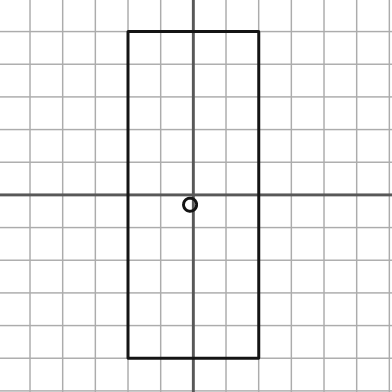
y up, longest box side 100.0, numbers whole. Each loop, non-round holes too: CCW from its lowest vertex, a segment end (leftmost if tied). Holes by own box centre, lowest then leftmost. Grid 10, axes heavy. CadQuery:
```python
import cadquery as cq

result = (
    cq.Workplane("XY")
    .moveTo(-20.0, -50.0)
    .lineTo(20.0, -50.0)
    .lineTo(20.0, 50.0)
    .lineTo(-20.0, 50.0)
    .close()
    .moveTo(-1.0, -3.0)
    .circle(2.0)
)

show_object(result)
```